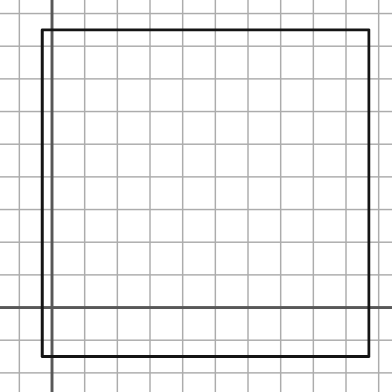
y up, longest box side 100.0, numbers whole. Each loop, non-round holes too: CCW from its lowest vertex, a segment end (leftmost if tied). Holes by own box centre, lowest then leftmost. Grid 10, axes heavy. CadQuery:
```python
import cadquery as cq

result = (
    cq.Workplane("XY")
    .moveTo(-3.0, -15.0)
    .lineTo(97.0, -15.0)
    .lineTo(97.0, 85.0)
    .lineTo(-3.0, 85.0)
    .close()
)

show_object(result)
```